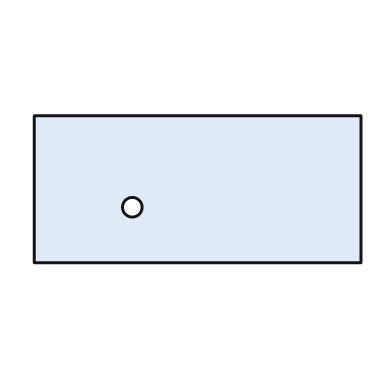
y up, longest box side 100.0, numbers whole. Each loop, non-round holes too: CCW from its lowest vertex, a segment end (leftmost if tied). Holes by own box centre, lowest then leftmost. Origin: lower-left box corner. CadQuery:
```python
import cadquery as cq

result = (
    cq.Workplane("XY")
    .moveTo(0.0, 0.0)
    .lineTo(100.0, 0.0)
    .lineTo(100.0, 45.0)
    .lineTo(0.0, 45.0)
    .close()
    .moveTo(30.0, 17.0)
    .circle(3.0)
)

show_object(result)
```